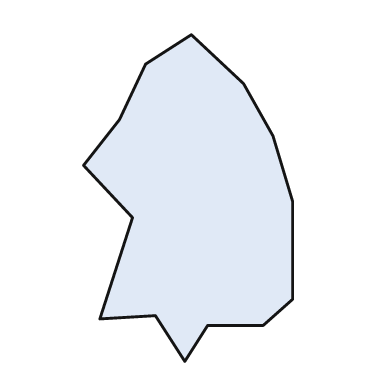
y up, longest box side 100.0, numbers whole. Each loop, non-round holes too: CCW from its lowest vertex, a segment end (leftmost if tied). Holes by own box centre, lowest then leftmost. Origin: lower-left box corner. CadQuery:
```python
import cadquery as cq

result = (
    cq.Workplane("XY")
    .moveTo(31.0, 0.0)
    .lineTo(38.0, 11.0)
    .lineTo(55.0, 11.0)
    .lineTo(64.0, 19.0)
    .lineTo(64.0, 49.0)
    .lineTo(58.0, 69.0)
    .lineTo(49.0, 85.0)
    .lineTo(33.0, 100.0)
    .lineTo(19.0, 91.0)
    .lineTo(11.0, 74.0)
    .lineTo(0.0, 60.0)
    .lineTo(15.0, 44.0)
    .lineTo(5.0, 13.0)
    .lineTo(22.0, 14.0)
    .close()
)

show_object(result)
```